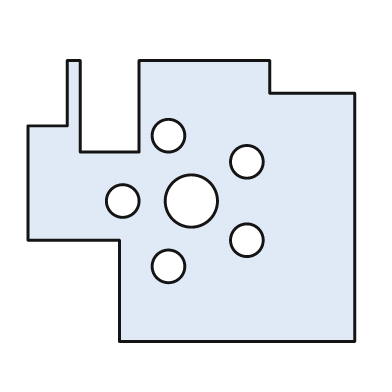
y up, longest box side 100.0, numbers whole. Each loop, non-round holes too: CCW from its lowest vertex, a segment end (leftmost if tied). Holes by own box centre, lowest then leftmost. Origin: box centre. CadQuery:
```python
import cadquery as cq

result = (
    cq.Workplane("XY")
    .moveTo(-22.0, -43.0)
    .lineTo(50.0, -43.0)
    .lineTo(50.0, 33.0)
    .lineTo(24.0, 33.0)
    .lineTo(24.0, 43.0)
    .lineTo(-16.0, 43.0)
    .lineTo(-16.0, 15.0)
    .lineTo(-34.0, 15.0)
    .lineTo(-34.0, 43.0)
    .lineTo(-38.0, 43.0)
    .lineTo(-38.0, 23.0)
    .lineTo(-50.0, 23.0)
    .lineTo(-50.0, -12.0)
    .lineTo(-22.0, -12.0)
    .close()
    .moveTo(-7.0, -20.0)
    .circle(5.0)
    .moveTo(17.0, -12.0)
    .circle(5.0)
    .moveTo(-21.0, 0.0)
    .circle(5.0)
    .moveTo(0.0, 0.0)
    .circle(8.0)
    .moveTo(17.0, 12.0)
    .circle(5.0)
    .moveTo(-7.0, 20.0)
    .circle(5.0)
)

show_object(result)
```